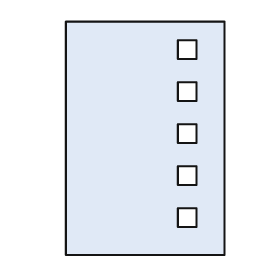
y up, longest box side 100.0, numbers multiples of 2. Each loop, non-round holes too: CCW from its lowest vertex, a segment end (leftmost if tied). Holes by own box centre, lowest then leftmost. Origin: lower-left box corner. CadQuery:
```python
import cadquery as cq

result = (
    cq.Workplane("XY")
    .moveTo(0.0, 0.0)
    .lineTo(68.0, 0.0)
    .lineTo(68.0, 100.0)
    .lineTo(0.0, 100.0)
    .close()
    .moveTo(48.0, 12.0)
    .lineTo(56.0, 12.0)
    .lineTo(56.0, 20.0)
    .lineTo(48.0, 20.0)
    .close()
    .moveTo(48.0, 30.0)
    .lineTo(56.0, 30.0)
    .lineTo(56.0, 38.0)
    .lineTo(48.0, 38.0)
    .close()
    .moveTo(48.0, 48.0)
    .lineTo(56.0, 48.0)
    .lineTo(56.0, 56.0)
    .lineTo(48.0, 56.0)
    .close()
    .moveTo(48.0, 66.0)
    .lineTo(56.0, 66.0)
    .lineTo(56.0, 74.0)
    .lineTo(48.0, 74.0)
    .close()
    .moveTo(48.0, 84.0)
    .lineTo(56.0, 84.0)
    .lineTo(56.0, 92.0)
    .lineTo(48.0, 92.0)
    .close()
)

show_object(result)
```